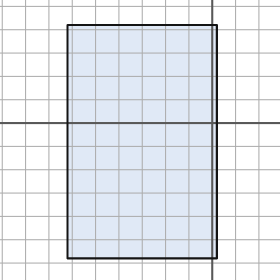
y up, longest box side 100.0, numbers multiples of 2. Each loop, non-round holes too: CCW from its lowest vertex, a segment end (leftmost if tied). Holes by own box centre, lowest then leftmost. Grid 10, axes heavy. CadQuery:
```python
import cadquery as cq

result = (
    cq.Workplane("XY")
    .moveTo(-62.0, -58.0)
    .lineTo(2.0, -58.0)
    .lineTo(2.0, 42.0)
    .lineTo(-62.0, 42.0)
    .close()
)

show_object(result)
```